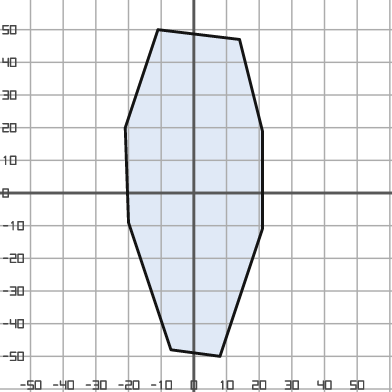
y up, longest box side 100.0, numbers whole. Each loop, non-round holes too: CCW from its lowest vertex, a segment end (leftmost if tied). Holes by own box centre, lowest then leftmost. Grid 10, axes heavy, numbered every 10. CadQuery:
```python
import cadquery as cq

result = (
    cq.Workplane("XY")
    .moveTo(8.0, -50.0)
    .lineTo(21.0, -11.0)
    .lineTo(21.0, 19.0)
    .lineTo(14.0, 47.0)
    .lineTo(-11.0, 50.0)
    .lineTo(-21.0, 20.0)
    .lineTo(-20.0, -9.0)
    .lineTo(-7.0, -48.0)
    .close()
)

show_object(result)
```